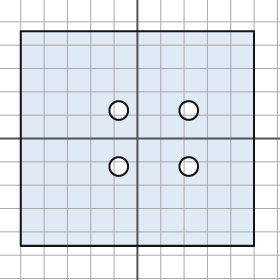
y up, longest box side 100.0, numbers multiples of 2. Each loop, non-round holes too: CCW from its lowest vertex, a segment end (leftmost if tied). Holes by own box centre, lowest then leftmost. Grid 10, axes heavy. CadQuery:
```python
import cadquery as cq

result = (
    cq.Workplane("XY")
    .moveTo(-50.0, -46.0)
    .lineTo(50.0, -46.0)
    .lineTo(50.0, 46.0)
    .lineTo(-50.0, 46.0)
    .close()
    .moveTo(-8.0, -12.0)
    .circle(4.0)
    .moveTo(22.0, -12.0)
    .circle(4.0)
    .moveTo(-8.0, 12.0)
    .circle(4.0)
    .moveTo(22.0, 12.0)
    .circle(4.0)
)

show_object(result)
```